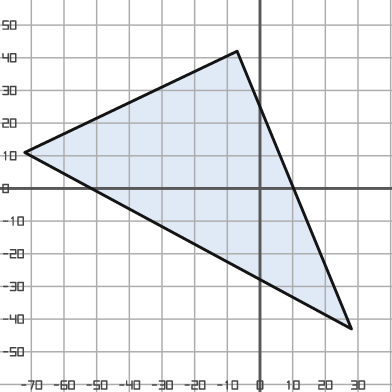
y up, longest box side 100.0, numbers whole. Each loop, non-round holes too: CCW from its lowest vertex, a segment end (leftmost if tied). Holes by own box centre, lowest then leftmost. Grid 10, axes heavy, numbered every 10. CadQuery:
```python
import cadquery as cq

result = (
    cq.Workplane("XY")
    .moveTo(28.0, -43.0)
    .lineTo(-7.0, 42.0)
    .lineTo(-72.0, 11.0)
    .close()
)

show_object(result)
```